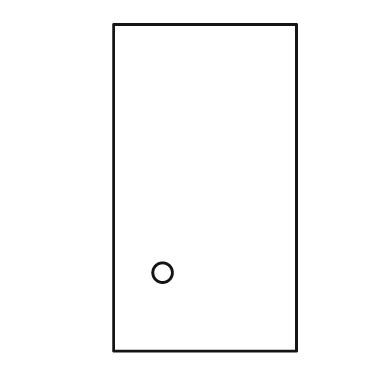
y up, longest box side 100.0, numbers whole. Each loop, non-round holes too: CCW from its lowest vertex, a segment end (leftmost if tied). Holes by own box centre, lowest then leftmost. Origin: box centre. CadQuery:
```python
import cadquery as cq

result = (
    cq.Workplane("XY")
    .moveTo(-28.0, -50.0)
    .lineTo(28.0, -50.0)
    .lineTo(28.0, 50.0)
    .lineTo(-28.0, 50.0)
    .close()
    .moveTo(-13.0, -26.0)
    .circle(3.0)
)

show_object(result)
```